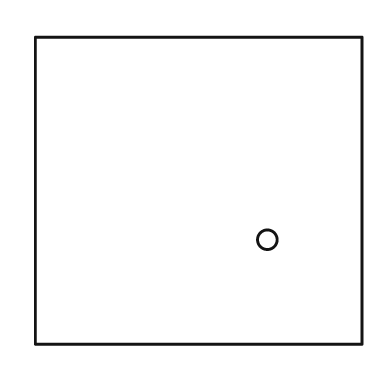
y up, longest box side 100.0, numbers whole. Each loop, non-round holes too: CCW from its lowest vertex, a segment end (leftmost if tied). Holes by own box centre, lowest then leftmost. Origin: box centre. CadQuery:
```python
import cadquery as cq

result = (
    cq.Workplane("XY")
    .moveTo(-50.0, -47.0)
    .lineTo(50.0, -47.0)
    .lineTo(50.0, 47.0)
    .lineTo(-50.0, 47.0)
    .close()
    .moveTo(21.0, -15.0)
    .circle(3.0)
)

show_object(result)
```